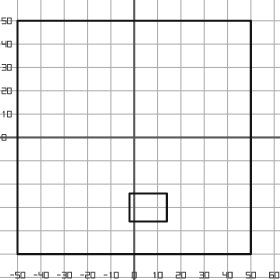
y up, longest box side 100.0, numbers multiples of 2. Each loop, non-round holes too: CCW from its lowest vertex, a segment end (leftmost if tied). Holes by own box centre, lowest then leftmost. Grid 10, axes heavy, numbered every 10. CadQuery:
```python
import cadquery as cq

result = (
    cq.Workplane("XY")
    .moveTo(-50.0, -50.0)
    .lineTo(50.0, -50.0)
    .lineTo(50.0, 50.0)
    .lineTo(-50.0, 50.0)
    .close()
    .moveTo(-2.0, -36.0)
    .lineTo(14.0, -36.0)
    .lineTo(14.0, -24.0)
    .lineTo(-2.0, -24.0)
    .close()
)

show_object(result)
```